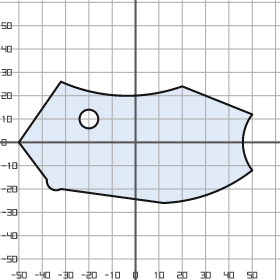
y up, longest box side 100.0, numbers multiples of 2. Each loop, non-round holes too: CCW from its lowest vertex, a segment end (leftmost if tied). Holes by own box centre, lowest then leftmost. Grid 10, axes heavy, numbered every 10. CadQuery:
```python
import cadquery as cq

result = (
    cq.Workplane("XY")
    .moveTo(12.0, -26.0)
    .threePointArc((32.0, -22.0), (50.0, -12.0))
    .threePointArc((46.0, 0.0), (50.0, 12.0))
    .lineTo(20.0, 24.0)
    .threePointArc((-6.0, 20.0), (-32.0, 26.0))
    .lineTo(-50.0, 0.0)
    .lineTo(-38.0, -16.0)
    .threePointArc((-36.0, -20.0), (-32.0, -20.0))
    .close()
    .moveTo(-20.0, 10.0)
    .circle(4.0)
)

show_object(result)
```